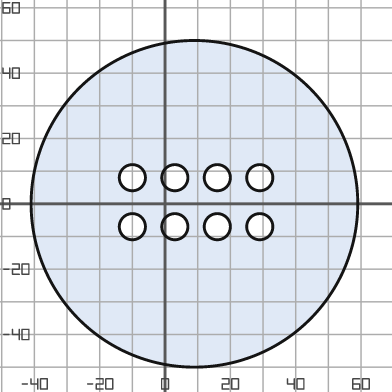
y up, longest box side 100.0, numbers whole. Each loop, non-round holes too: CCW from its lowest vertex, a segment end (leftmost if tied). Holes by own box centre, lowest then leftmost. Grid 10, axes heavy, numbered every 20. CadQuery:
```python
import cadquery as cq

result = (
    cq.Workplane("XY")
    .moveTo(9.0, 0.0)
    .circle(50.0)
    .moveTo(-10.0, -7.0)
    .circle(4.0)
    .moveTo(3.0, -7.0)
    .circle(4.0)
    .moveTo(16.0, -7.0)
    .circle(4.0)
    .moveTo(29.0, -7.0)
    .circle(4.0)
    .moveTo(-10.0, 8.0)
    .circle(4.0)
    .moveTo(3.0, 8.0)
    .circle(4.0)
    .moveTo(16.0, 8.0)
    .circle(4.0)
    .moveTo(29.0, 8.0)
    .circle(4.0)
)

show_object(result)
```